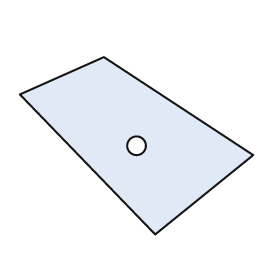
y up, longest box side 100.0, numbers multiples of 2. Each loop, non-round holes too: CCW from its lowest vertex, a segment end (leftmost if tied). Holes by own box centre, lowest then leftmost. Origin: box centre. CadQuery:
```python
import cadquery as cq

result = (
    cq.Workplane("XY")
    .moveTo(8.0, -38.0)
    .lineTo(50.0, -4.0)
    .lineTo(-14.0, 38.0)
    .lineTo(-50.0, 22.0)
    .close()
    .moveTo(0.0, 0.0)
    .circle(4.0)
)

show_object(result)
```